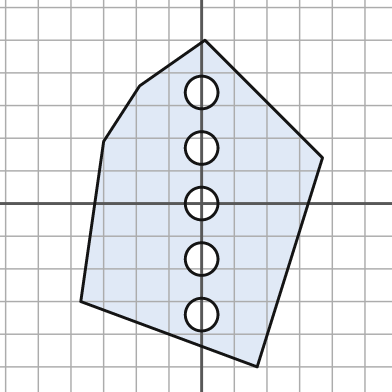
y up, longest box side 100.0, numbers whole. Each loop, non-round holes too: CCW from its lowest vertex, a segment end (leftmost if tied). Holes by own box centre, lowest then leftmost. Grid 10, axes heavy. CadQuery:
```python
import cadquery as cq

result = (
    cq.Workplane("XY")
    .moveTo(17.0, -50.0)
    .lineTo(37.0, 14.0)
    .lineTo(1.0, 50.0)
    .lineTo(-19.0, 36.0)
    .lineTo(-30.0, 19.0)
    .lineTo(-37.0, -30.0)
    .close()
    .moveTo(0.0, -34.0)
    .circle(5.0)
    .moveTo(0.0, -17.0)
    .circle(5.0)
    .moveTo(0.0, 0.0)
    .circle(5.0)
    .moveTo(0.0, 17.0)
    .circle(5.0)
    .moveTo(0.0, 34.0)
    .circle(5.0)
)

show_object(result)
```